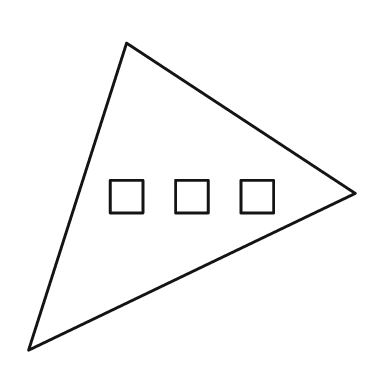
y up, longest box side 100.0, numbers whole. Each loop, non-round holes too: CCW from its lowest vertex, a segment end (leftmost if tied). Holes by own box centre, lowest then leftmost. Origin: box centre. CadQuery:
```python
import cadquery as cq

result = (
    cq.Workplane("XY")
    .moveTo(-50.0, -47.0)
    .lineTo(50.0, 1.0)
    .lineTo(-20.0, 47.0)
    .close()
    .moveTo(-25.0, -5.0)
    .lineTo(-15.0, -5.0)
    .lineTo(-15.0, 5.0)
    .lineTo(-25.0, 5.0)
    .close()
    .moveTo(-5.0, -5.0)
    .lineTo(5.0, -5.0)
    .lineTo(5.0, 5.0)
    .lineTo(-5.0, 5.0)
    .close()
    .moveTo(15.0, -5.0)
    .lineTo(25.0, -5.0)
    .lineTo(25.0, 5.0)
    .lineTo(15.0, 5.0)
    .close()
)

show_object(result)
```